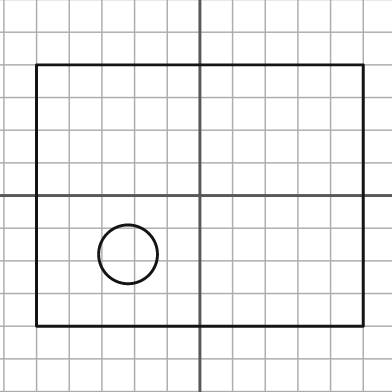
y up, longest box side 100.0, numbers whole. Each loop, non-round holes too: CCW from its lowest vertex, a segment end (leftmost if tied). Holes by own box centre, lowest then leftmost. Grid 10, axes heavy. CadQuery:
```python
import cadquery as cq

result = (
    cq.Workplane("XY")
    .moveTo(-50.0, -40.0)
    .lineTo(50.0, -40.0)
    .lineTo(50.0, 40.0)
    .lineTo(-50.0, 40.0)
    .close()
    .moveTo(-22.0, -18.0)
    .circle(9.0)
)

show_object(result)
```